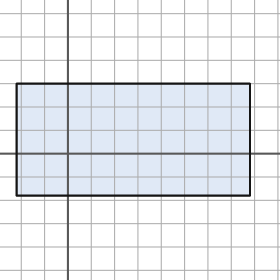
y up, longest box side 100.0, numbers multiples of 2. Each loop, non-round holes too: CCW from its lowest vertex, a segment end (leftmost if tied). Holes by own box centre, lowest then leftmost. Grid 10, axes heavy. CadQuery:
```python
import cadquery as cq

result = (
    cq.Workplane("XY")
    .moveTo(-22.0, -18.0)
    .lineTo(78.0, -18.0)
    .lineTo(78.0, 30.0)
    .lineTo(-22.0, 30.0)
    .close()
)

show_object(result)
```